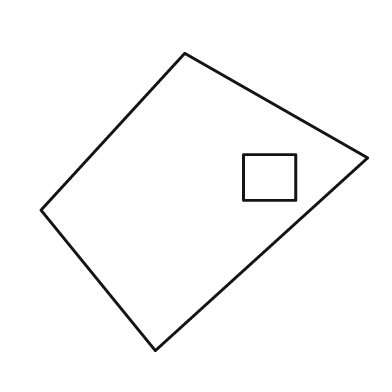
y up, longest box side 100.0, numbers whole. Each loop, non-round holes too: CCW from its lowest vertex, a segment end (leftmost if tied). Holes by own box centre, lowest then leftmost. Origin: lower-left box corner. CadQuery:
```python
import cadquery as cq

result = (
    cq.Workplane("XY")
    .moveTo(35.0, 0.0)
    .lineTo(100.0, 59.0)
    .lineTo(44.0, 91.0)
    .lineTo(0.0, 43.0)
    .close()
    .moveTo(62.0, 46.0)
    .lineTo(78.0, 46.0)
    .lineTo(78.0, 60.0)
    .lineTo(62.0, 60.0)
    .close()
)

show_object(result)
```